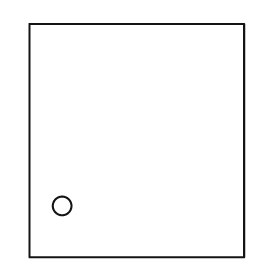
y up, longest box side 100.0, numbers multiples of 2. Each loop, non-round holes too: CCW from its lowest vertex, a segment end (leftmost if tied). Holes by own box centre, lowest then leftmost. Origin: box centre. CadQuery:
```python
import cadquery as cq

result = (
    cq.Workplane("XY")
    .moveTo(-46.0, -50.0)
    .lineTo(46.0, -50.0)
    .lineTo(46.0, 50.0)
    .lineTo(-46.0, 50.0)
    .close()
    .moveTo(-32.0, -28.0)
    .circle(4.0)
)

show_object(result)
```